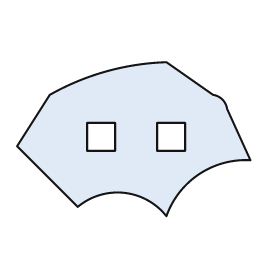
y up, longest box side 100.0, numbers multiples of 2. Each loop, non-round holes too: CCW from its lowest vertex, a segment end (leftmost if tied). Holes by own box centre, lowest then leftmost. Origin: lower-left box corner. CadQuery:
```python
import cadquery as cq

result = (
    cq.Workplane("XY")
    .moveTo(64.0, 0.0)
    .threePointArc((78.0, 18.0), (100.0, 24.0))
    .lineTo(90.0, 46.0)
    .threePointArc((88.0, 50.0), (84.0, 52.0))
    .lineTo(64.0, 66.0)
    .threePointArc((38.0, 62.0), (14.0, 52.0))
    .lineTo(0.0, 30.0)
    .lineTo(26.0, 4.0)
    .threePointArc((46.0, 10.0), (64.0, 0.0))
    .close()
    .moveTo(30.0, 28.0)
    .lineTo(42.0, 28.0)
    .lineTo(42.0, 40.0)
    .lineTo(30.0, 40.0)
    .close()
    .moveTo(60.0, 28.0)
    .lineTo(72.0, 28.0)
    .lineTo(72.0, 40.0)
    .lineTo(60.0, 40.0)
    .close()
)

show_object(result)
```